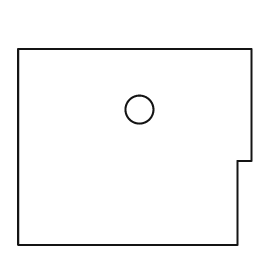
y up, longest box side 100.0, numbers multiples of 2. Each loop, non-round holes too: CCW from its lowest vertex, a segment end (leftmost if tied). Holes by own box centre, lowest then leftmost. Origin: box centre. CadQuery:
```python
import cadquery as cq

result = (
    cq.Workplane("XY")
    .moveTo(-50.0, -42.0)
    .lineTo(44.0, -42.0)
    .lineTo(44.0, -6.0)
    .lineTo(50.0, -6.0)
    .lineTo(50.0, 42.0)
    .lineTo(-50.0, 42.0)
    .close()
    .moveTo(2.0, 16.0)
    .circle(6.0)
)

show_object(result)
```